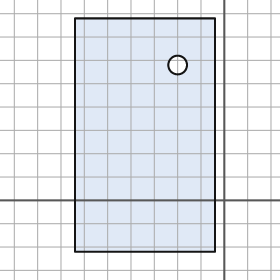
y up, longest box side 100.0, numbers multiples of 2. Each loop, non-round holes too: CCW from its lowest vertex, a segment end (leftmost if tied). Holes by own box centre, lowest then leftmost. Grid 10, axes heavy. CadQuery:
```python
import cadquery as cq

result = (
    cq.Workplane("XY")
    .moveTo(-64.0, -22.0)
    .lineTo(-4.0, -22.0)
    .lineTo(-4.0, 78.0)
    .lineTo(-64.0, 78.0)
    .close()
    .moveTo(-20.0, 58.0)
    .circle(4.0)
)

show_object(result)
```